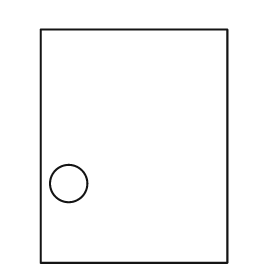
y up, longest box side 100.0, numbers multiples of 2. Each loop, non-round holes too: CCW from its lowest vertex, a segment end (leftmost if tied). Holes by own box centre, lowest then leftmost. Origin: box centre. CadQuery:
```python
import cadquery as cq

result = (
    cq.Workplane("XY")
    .moveTo(-40.0, -50.0)
    .lineTo(40.0, -50.0)
    .lineTo(40.0, 50.0)
    .lineTo(-40.0, 50.0)
    .close()
    .moveTo(-28.0, -16.0)
    .circle(8.0)
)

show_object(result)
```